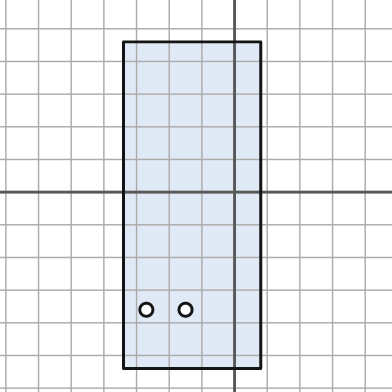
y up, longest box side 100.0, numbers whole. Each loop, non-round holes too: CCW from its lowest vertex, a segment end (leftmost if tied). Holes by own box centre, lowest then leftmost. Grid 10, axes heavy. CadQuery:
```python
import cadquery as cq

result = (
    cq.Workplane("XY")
    .moveTo(-34.0, -54.0)
    .lineTo(8.0, -54.0)
    .lineTo(8.0, 46.0)
    .lineTo(-34.0, 46.0)
    .close()
    .moveTo(-27.0, -36.0)
    .circle(2.0)
    .moveTo(-15.0, -36.0)
    .circle(2.0)
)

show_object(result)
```